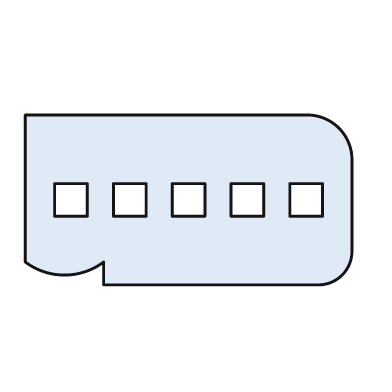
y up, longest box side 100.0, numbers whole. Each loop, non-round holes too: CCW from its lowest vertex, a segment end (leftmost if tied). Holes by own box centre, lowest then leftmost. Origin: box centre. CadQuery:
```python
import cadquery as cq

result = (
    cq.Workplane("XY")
    .moveTo(-26.0, -26.0)
    .lineTo(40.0, -26.0)
    .threePointArc((47.0, -23.0), (50.0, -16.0))
    .lineTo(50.0, 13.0)
    .threePointArc((46.0, 22.0), (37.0, 26.0))
    .lineTo(-50.0, 26.0)
    .lineTo(-50.0, -19.0)
    .threePointArc((-38.0, -23.0), (-26.0, -19.0))
    .close()
    .moveTo(-41.0, -5.0)
    .lineTo(-31.0, -5.0)
    .lineTo(-31.0, 5.0)
    .lineTo(-41.0, 5.0)
    .close()
    .moveTo(-23.0, -5.0)
    .lineTo(-13.0, -5.0)
    .lineTo(-13.0, 5.0)
    .lineTo(-23.0, 5.0)
    .close()
    .moveTo(-5.0, -5.0)
    .lineTo(5.0, -5.0)
    .lineTo(5.0, 5.0)
    .lineTo(-5.0, 5.0)
    .close()
    .moveTo(13.0, -5.0)
    .lineTo(23.0, -5.0)
    .lineTo(23.0, 5.0)
    .lineTo(13.0, 5.0)
    .close()
    .moveTo(31.0, -5.0)
    .lineTo(41.0, -5.0)
    .lineTo(41.0, 5.0)
    .lineTo(31.0, 5.0)
    .close()
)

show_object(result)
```